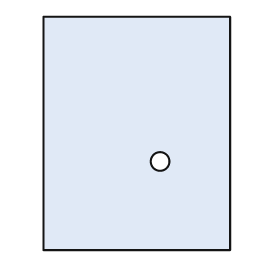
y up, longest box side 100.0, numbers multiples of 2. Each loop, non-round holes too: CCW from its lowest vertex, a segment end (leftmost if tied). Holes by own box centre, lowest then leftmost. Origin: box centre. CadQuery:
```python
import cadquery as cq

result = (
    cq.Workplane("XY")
    .moveTo(-40.0, -50.0)
    .lineTo(40.0, -50.0)
    .lineTo(40.0, 50.0)
    .lineTo(-40.0, 50.0)
    .close()
    .moveTo(10.0, -12.0)
    .circle(4.0)
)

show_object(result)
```